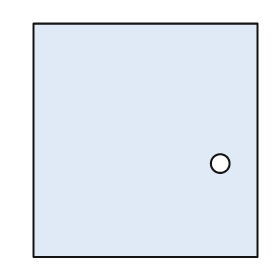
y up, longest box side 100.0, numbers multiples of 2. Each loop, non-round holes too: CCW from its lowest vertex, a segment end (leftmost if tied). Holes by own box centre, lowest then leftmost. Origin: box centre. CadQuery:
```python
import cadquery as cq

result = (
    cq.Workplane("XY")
    .moveTo(-48.0, -50.0)
    .lineTo(48.0, -50.0)
    .lineTo(48.0, 50.0)
    .lineTo(-48.0, 50.0)
    .close()
    .moveTo(32.0, -10.0)
    .circle(4.0)
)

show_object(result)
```